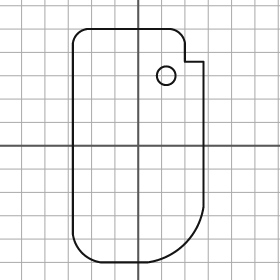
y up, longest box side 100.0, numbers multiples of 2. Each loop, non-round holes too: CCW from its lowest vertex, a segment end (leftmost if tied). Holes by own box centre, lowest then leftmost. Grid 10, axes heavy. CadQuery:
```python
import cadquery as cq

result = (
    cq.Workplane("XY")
    .moveTo(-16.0, -50.0)
    .lineTo(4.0, -50.0)
    .threePointArc((20.0, -42.0), (28.0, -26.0))
    .lineTo(28.0, 36.0)
    .lineTo(20.0, 36.0)
    .lineTo(20.0, 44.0)
    .threePointArc((18.0, 48.0), (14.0, 50.0))
    .lineTo(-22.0, 50.0)
    .threePointArc((-26.0, 48.0), (-28.0, 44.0))
    .lineTo(-28.0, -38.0)
    .threePointArc((-24.0, -46.0), (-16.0, -50.0))
    .close()
    .moveTo(12.0, 30.0)
    .circle(4.0)
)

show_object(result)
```